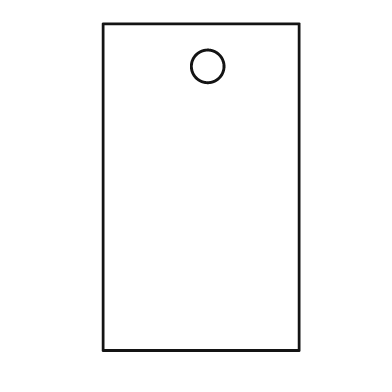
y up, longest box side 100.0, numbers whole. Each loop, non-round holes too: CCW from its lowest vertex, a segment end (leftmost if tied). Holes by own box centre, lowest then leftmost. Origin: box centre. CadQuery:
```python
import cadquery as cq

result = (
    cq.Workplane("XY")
    .moveTo(-30.0, -50.0)
    .lineTo(30.0, -50.0)
    .lineTo(30.0, 50.0)
    .lineTo(-30.0, 50.0)
    .close()
    .moveTo(2.0, 37.0)
    .circle(5.0)
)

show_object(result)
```